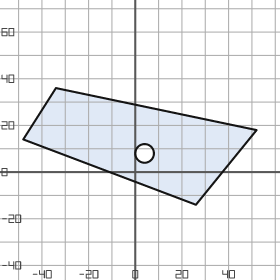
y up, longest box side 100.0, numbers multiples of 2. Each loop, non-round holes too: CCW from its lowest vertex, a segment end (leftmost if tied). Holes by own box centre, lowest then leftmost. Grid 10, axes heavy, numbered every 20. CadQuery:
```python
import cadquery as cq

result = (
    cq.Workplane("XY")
    .moveTo(26.0, -14.0)
    .lineTo(52.0, 18.0)
    .lineTo(-34.0, 36.0)
    .lineTo(-48.0, 14.0)
    .close()
    .moveTo(4.0, 8.0)
    .circle(4.0)
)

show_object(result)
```